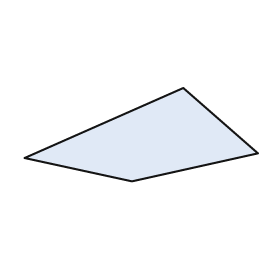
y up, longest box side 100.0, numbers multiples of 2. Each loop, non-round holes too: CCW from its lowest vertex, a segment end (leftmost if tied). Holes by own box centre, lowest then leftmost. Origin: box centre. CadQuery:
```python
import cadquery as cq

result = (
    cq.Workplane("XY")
    .moveTo(-4.0, -20.0)
    .lineTo(50.0, -8.0)
    .lineTo(18.0, 20.0)
    .lineTo(-50.0, -10.0)
    .close()
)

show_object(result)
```